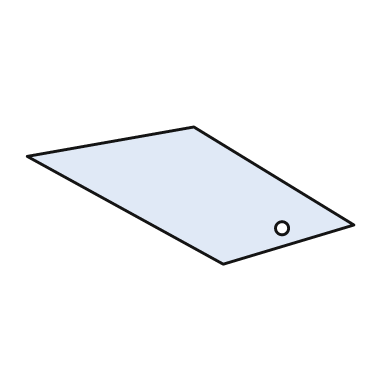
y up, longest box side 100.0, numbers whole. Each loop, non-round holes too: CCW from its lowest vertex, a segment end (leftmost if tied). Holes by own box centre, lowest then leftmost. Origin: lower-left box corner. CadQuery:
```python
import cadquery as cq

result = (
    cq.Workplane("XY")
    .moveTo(60.0, 0.0)
    .lineTo(100.0, 12.0)
    .lineTo(51.0, 42.0)
    .lineTo(0.0, 33.0)
    .close()
    .moveTo(78.0, 11.0)
    .circle(2.0)
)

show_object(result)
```